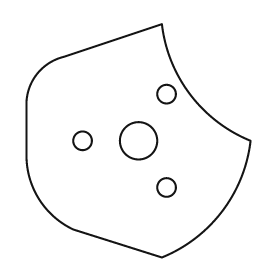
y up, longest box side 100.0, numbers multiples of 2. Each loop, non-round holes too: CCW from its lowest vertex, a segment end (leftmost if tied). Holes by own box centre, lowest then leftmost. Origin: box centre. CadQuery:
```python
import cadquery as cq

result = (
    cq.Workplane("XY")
    .moveTo(10.0, -50.0)
    .threePointArc((36.0, -30.0), (48.0, 0.0))
    .threePointArc((22.0, 20.0), (10.0, 50.0))
    .lineTo(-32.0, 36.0)
    .threePointArc((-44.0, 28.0), (-48.0, 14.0))
    .lineTo(-48.0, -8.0)
    .threePointArc((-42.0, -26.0), (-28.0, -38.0))
    .close()
    .moveTo(12.0, -20.0)
    .circle(4.0)
    .moveTo(-24.0, 0.0)
    .circle(4.0)
    .moveTo(0.0, 0.0)
    .circle(8.0)
    .moveTo(12.0, 20.0)
    .circle(4.0)
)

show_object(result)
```